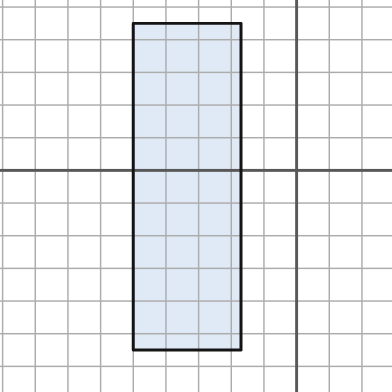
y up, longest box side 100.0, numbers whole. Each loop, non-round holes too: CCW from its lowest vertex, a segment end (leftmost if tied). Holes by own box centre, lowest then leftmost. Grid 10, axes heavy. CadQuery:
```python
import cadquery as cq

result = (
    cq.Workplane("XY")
    .moveTo(-50.0, -55.0)
    .lineTo(-17.0, -55.0)
    .lineTo(-17.0, 45.0)
    .lineTo(-50.0, 45.0)
    .close()
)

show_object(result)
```